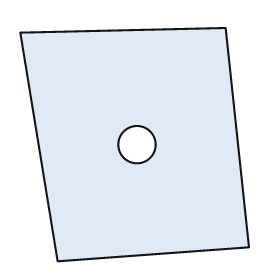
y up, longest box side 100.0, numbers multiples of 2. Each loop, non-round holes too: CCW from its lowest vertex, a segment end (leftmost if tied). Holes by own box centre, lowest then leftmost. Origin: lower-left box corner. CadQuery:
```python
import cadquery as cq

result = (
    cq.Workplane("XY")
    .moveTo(16.0, 0.0)
    .lineTo(98.0, 6.0)
    .lineTo(88.0, 100.0)
    .lineTo(0.0, 98.0)
    .close()
    .moveTo(50.0, 50.0)
    .circle(8.0)
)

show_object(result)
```